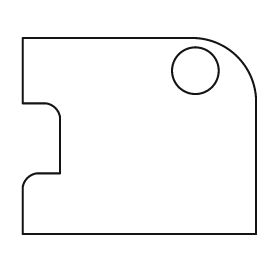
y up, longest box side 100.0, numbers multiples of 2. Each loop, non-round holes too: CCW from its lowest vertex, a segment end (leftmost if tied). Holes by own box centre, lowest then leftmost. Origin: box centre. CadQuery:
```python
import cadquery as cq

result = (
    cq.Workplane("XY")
    .moveTo(-50.0, -42.0)
    .lineTo(50.0, -42.0)
    .lineTo(50.0, 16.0)
    .threePointArc((42.0, 34.0), (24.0, 42.0))
    .lineTo(-50.0, 42.0)
    .lineTo(-50.0, 14.0)
    .lineTo(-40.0, 14.0)
    .threePointArc((-36.0, 12.0), (-34.0, 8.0))
    .lineTo(-34.0, -16.0)
    .lineTo(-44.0, -16.0)
    .threePointArc((-48.0, -18.0), (-50.0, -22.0))
    .close()
    .moveTo(24.0, 28.0)
    .circle(10.0)
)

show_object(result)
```